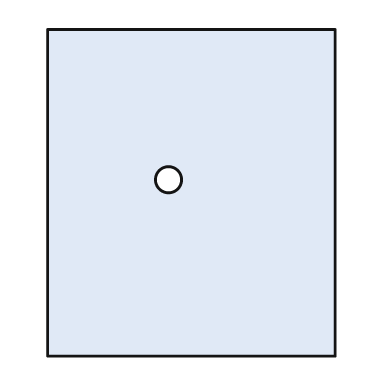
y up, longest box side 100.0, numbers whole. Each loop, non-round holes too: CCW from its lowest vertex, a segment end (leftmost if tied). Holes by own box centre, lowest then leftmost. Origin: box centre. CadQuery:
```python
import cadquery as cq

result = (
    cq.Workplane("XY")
    .moveTo(-44.0, -50.0)
    .lineTo(44.0, -50.0)
    .lineTo(44.0, 50.0)
    .lineTo(-44.0, 50.0)
    .close()
    .moveTo(-7.0, 4.0)
    .circle(4.0)
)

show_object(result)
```